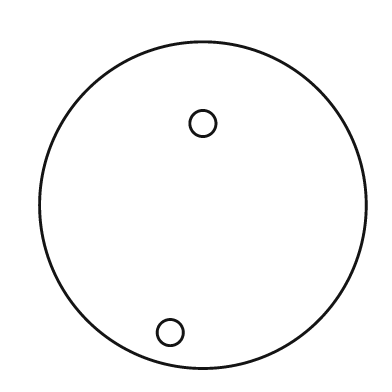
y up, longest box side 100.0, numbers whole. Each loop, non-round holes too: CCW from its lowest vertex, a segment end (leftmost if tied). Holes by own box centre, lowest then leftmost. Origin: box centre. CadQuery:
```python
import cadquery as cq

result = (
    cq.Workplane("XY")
    .moveTo(0.0, 0.0)
    .circle(50.0)
    .moveTo(-10.0, -39.0)
    .circle(4.0)
    .moveTo(0.0, 25.0)
    .circle(4.0)
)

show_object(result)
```